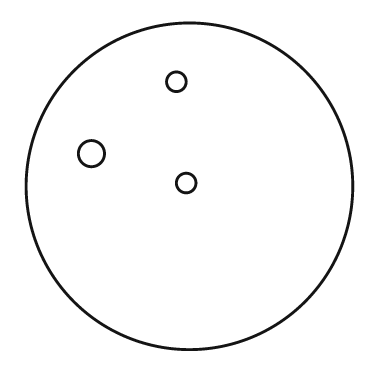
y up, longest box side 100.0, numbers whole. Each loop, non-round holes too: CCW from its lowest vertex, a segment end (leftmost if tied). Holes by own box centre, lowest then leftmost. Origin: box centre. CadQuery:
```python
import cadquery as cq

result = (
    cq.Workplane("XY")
    .moveTo(0.0, 0.0)
    .circle(50.0)
    .moveTo(-1.0, 1.0)
    .circle(3.0)
    .moveTo(-30.0, 10.0)
    .circle(4.0)
    .moveTo(-4.0, 32.0)
    .circle(3.0)
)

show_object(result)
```